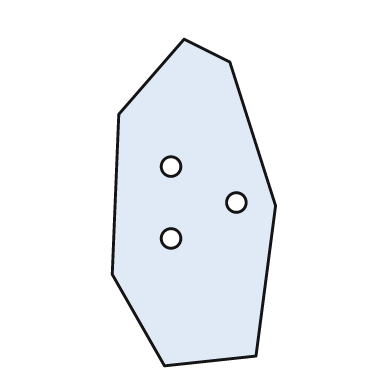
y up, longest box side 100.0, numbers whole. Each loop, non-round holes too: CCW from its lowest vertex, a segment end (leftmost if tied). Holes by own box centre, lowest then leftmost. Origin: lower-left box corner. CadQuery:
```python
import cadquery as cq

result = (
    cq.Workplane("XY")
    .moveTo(16.0, 0.0)
    .lineTo(44.0, 3.0)
    .lineTo(50.0, 49.0)
    .lineTo(36.0, 93.0)
    .lineTo(22.0, 100.0)
    .lineTo(2.0, 77.0)
    .lineTo(0.0, 28.0)
    .close()
    .moveTo(18.0, 39.0)
    .circle(3.0)
    .moveTo(38.0, 50.0)
    .circle(3.0)
    .moveTo(18.0, 61.0)
    .circle(3.0)
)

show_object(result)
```